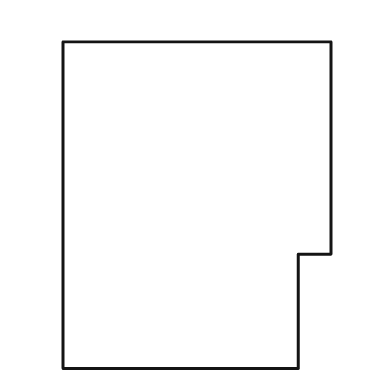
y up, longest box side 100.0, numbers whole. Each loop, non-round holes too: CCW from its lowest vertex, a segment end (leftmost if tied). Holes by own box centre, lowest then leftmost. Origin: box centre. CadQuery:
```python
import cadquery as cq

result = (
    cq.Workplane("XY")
    .moveTo(-41.0, -50.0)
    .lineTo(31.0, -50.0)
    .lineTo(31.0, -15.0)
    .lineTo(41.0, -15.0)
    .lineTo(41.0, 50.0)
    .lineTo(-41.0, 50.0)
    .close()
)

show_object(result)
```